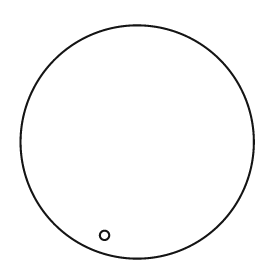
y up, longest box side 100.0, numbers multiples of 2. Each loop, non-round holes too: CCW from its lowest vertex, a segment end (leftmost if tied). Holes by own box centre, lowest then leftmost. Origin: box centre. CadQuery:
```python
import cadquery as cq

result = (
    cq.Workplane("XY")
    .moveTo(0.0, 0.0)
    .circle(50.0)
    .moveTo(-14.0, -40.0)
    .circle(2.0)
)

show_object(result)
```